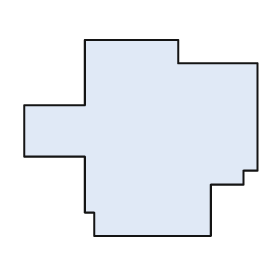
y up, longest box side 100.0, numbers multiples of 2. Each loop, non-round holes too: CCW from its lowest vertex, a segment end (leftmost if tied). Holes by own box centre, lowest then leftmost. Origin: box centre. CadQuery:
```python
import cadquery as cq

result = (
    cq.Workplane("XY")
    .moveTo(-20.0, -42.0)
    .lineTo(30.0, -42.0)
    .lineTo(30.0, -20.0)
    .lineTo(44.0, -20.0)
    .lineTo(44.0, -14.0)
    .lineTo(50.0, -14.0)
    .lineTo(50.0, 32.0)
    .lineTo(16.0, 32.0)
    .lineTo(16.0, 42.0)
    .lineTo(-24.0, 42.0)
    .lineTo(-24.0, 14.0)
    .lineTo(-50.0, 14.0)
    .lineTo(-50.0, -8.0)
    .lineTo(-24.0, -8.0)
    .lineTo(-24.0, -32.0)
    .lineTo(-20.0, -32.0)
    .close()
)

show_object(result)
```